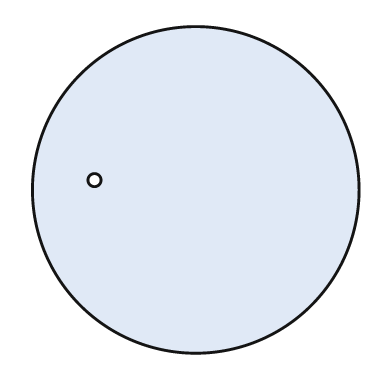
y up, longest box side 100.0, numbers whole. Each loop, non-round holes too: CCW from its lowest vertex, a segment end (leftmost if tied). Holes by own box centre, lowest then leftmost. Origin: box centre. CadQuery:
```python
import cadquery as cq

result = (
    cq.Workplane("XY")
    .moveTo(0.0, 0.0)
    .circle(50.0)
    .moveTo(-31.0, 3.0)
    .circle(2.0)
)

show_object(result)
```